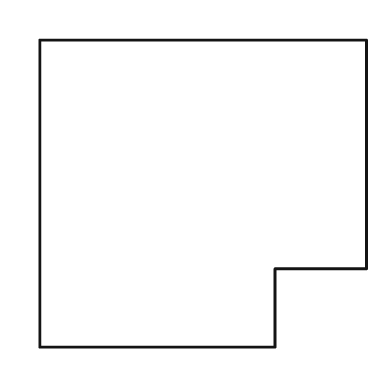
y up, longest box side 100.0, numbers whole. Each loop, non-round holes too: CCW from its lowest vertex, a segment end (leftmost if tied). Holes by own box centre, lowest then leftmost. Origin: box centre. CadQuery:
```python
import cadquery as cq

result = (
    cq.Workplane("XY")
    .moveTo(-50.0, -47.0)
    .lineTo(22.0, -47.0)
    .lineTo(22.0, -23.0)
    .lineTo(50.0, -23.0)
    .lineTo(50.0, 47.0)
    .lineTo(-50.0, 47.0)
    .close()
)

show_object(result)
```